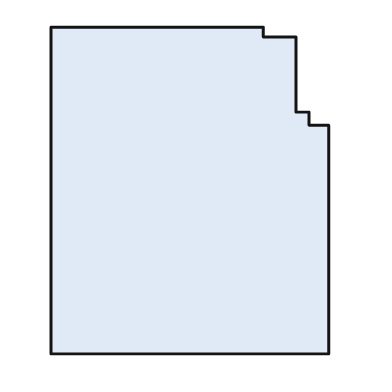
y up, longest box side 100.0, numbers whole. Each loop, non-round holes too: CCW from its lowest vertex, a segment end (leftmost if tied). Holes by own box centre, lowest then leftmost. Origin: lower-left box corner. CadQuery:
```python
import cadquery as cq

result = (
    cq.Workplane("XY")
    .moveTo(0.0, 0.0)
    .lineTo(85.0, 0.0)
    .lineTo(85.0, 70.0)
    .lineTo(79.0, 70.0)
    .lineTo(79.0, 74.0)
    .lineTo(75.0, 74.0)
    .lineTo(75.0, 97.0)
    .lineTo(65.0, 97.0)
    .lineTo(65.0, 100.0)
    .lineTo(0.0, 100.0)
    .close()
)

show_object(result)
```